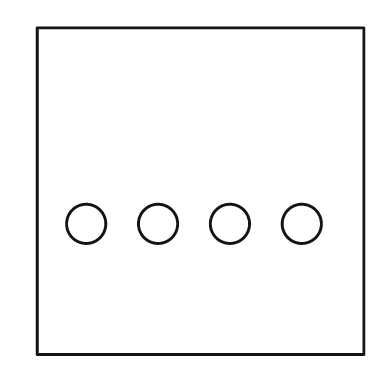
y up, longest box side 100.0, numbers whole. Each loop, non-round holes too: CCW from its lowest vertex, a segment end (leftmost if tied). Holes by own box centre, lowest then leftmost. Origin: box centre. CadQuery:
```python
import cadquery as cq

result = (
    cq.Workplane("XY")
    .moveTo(-50.0, -50.0)
    .lineTo(50.0, -50.0)
    .lineTo(50.0, 50.0)
    .lineTo(-50.0, 50.0)
    .close()
    .moveTo(-35.0, -10.0)
    .circle(6.0)
    .moveTo(-13.0, -10.0)
    .circle(6.0)
    .moveTo(9.0, -10.0)
    .circle(6.0)
    .moveTo(31.0, -10.0)
    .circle(6.0)
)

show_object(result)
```